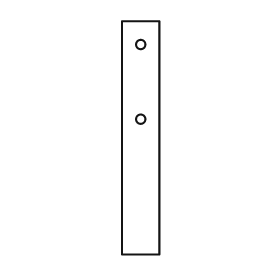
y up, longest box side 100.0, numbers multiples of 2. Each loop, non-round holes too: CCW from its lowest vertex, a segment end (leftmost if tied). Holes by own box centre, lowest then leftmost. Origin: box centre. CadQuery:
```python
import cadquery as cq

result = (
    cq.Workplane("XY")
    .moveTo(-8.0, -50.0)
    .lineTo(8.0, -50.0)
    .lineTo(8.0, 50.0)
    .lineTo(-8.0, 50.0)
    .close()
    .moveTo(0.0, 8.0)
    .circle(2.0)
    .moveTo(0.0, 40.0)
    .circle(2.0)
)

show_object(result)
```